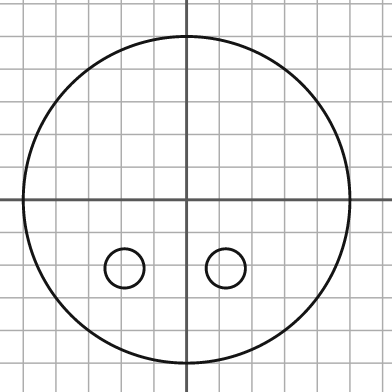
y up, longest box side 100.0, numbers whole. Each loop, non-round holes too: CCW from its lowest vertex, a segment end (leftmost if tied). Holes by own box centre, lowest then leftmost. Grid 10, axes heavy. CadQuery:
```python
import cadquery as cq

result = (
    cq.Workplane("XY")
    .moveTo(0.0, 0.0)
    .circle(50.0)
    .moveTo(-19.0, -21.0)
    .circle(6.0)
    .moveTo(12.0, -21.0)
    .circle(6.0)
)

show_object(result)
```